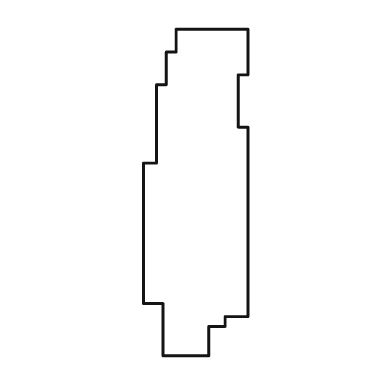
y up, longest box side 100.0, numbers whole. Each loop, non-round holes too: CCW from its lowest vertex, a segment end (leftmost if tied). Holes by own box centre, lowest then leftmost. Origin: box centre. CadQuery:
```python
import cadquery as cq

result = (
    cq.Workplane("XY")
    .moveTo(-10.0, -50.0)
    .lineTo(4.0, -50.0)
    .lineTo(4.0, -41.0)
    .lineTo(9.0, -41.0)
    .lineTo(9.0, -38.0)
    .lineTo(16.0, -38.0)
    .lineTo(16.0, 20.0)
    .lineTo(13.0, 20.0)
    .lineTo(13.0, 36.0)
    .lineTo(16.0, 36.0)
    .lineTo(16.0, 50.0)
    .lineTo(-6.0, 50.0)
    .lineTo(-6.0, 43.0)
    .lineTo(-9.0, 43.0)
    .lineTo(-9.0, 33.0)
    .lineTo(-12.0, 33.0)
    .lineTo(-12.0, 9.0)
    .lineTo(-16.0, 9.0)
    .lineTo(-16.0, -34.0)
    .lineTo(-10.0, -34.0)
    .close()
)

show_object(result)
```